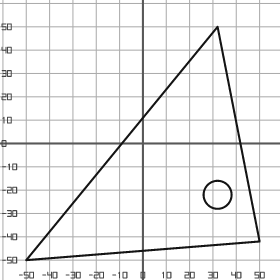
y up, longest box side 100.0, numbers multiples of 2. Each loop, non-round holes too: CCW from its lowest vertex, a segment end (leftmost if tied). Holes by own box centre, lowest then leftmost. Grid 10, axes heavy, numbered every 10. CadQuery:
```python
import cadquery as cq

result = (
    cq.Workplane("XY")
    .moveTo(-50.0, -50.0)
    .lineTo(50.0, -42.0)
    .lineTo(32.0, 50.0)
    .close()
    .moveTo(32.0, -22.0)
    .circle(6.0)
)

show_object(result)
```